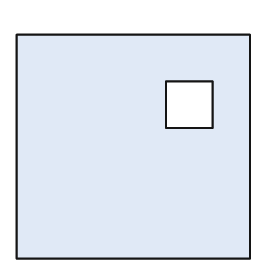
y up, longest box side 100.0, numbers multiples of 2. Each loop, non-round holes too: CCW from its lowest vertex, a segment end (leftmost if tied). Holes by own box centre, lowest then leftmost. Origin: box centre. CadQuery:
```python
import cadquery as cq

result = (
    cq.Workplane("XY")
    .moveTo(-50.0, -48.0)
    .lineTo(50.0, -48.0)
    .lineTo(50.0, 48.0)
    .lineTo(-50.0, 48.0)
    .close()
    .moveTo(14.0, 8.0)
    .lineTo(34.0, 8.0)
    .lineTo(34.0, 28.0)
    .lineTo(14.0, 28.0)
    .close()
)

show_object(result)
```